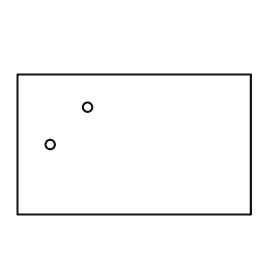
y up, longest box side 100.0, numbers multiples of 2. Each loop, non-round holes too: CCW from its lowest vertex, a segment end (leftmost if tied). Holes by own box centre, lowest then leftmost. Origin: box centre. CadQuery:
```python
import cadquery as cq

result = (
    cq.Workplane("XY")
    .moveTo(-50.0, -30.0)
    .lineTo(50.0, -30.0)
    .lineTo(50.0, 30.0)
    .lineTo(-50.0, 30.0)
    .close()
    .moveTo(-36.0, 0.0)
    .circle(2.0)
    .moveTo(-20.0, 16.0)
    .circle(2.0)
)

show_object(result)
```